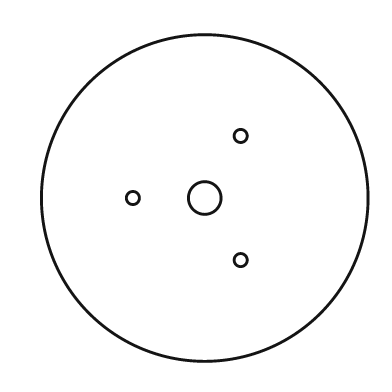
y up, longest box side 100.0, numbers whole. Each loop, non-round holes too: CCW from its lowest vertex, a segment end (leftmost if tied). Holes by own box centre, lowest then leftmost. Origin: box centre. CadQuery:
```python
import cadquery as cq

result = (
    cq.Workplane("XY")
    .moveTo(0.0, 0.0)
    .circle(50.0)
    .moveTo(11.0, -19.0)
    .circle(2.0)
    .moveTo(-22.0, 0.0)
    .circle(2.0)
    .moveTo(0.0, 0.0)
    .circle(5.0)
    .moveTo(11.0, 19.0)
    .circle(2.0)
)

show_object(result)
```